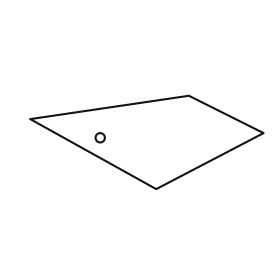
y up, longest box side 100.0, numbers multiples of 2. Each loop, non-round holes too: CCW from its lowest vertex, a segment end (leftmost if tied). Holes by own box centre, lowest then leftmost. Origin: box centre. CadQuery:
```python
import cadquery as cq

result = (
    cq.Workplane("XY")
    .moveTo(4.0, -20.0)
    .lineTo(50.0, 4.0)
    .lineTo(18.0, 20.0)
    .lineTo(-50.0, 10.0)
    .close()
    .moveTo(-20.0, 2.0)
    .circle(2.0)
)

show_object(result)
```